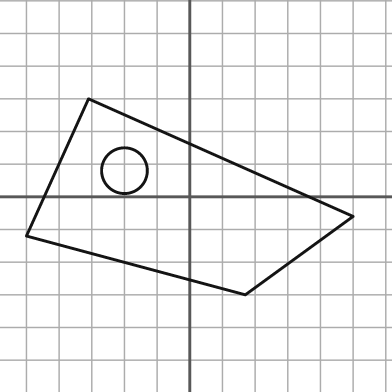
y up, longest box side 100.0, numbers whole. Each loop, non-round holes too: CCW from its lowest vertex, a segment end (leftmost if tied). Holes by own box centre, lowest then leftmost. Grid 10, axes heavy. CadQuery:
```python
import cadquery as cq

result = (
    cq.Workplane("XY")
    .moveTo(17.0, -30.0)
    .lineTo(50.0, -6.0)
    .lineTo(-31.0, 30.0)
    .lineTo(-50.0, -12.0)
    .close()
    .moveTo(-20.0, 8.0)
    .circle(7.0)
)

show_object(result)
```